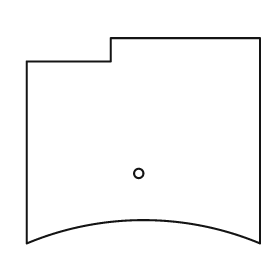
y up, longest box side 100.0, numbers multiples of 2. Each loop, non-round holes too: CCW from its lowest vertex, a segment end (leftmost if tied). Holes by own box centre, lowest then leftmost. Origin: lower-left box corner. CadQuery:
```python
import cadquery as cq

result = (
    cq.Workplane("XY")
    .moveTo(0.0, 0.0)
    .threePointArc((50.0, 10.0), (100.0, 0.0))
    .lineTo(100.0, 88.0)
    .lineTo(36.0, 88.0)
    .lineTo(36.0, 78.0)
    .lineTo(0.0, 78.0)
    .close()
    .moveTo(48.0, 30.0)
    .circle(2.0)
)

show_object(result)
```